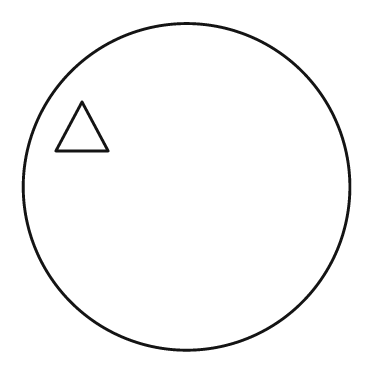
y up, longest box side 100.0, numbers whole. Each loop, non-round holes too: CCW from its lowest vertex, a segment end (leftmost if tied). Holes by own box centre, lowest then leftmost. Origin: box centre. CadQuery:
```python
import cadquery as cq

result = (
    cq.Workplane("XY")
    .moveTo(0.0, 0.0)
    .circle(50.0)
    .moveTo(-40.0, 11.0)
    .lineTo(-24.0, 11.0)
    .lineTo(-32.0, 26.0)
    .close()
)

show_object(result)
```